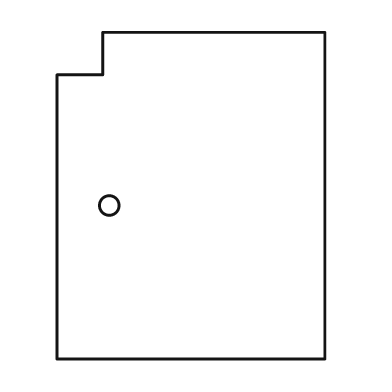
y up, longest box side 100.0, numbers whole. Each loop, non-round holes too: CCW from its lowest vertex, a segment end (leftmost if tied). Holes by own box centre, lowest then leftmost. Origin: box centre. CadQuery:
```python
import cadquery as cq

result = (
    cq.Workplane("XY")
    .moveTo(-41.0, -50.0)
    .lineTo(41.0, -50.0)
    .lineTo(41.0, 50.0)
    .lineTo(-27.0, 50.0)
    .lineTo(-27.0, 37.0)
    .lineTo(-41.0, 37.0)
    .close()
    .moveTo(-25.0, -3.0)
    .circle(3.0)
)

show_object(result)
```